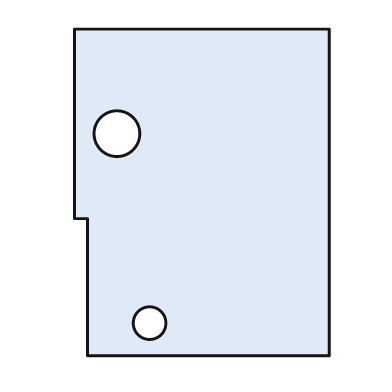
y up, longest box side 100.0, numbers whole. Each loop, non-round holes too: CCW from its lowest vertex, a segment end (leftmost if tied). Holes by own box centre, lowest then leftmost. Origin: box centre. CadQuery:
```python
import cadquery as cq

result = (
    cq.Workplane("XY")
    .moveTo(-35.0, -50.0)
    .lineTo(39.0, -50.0)
    .lineTo(39.0, 50.0)
    .lineTo(-39.0, 50.0)
    .lineTo(-39.0, -8.0)
    .lineTo(-35.0, -8.0)
    .close()
    .moveTo(-16.0, -40.0)
    .circle(5.0)
    .moveTo(-26.0, 18.0)
    .circle(7.0)
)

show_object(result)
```